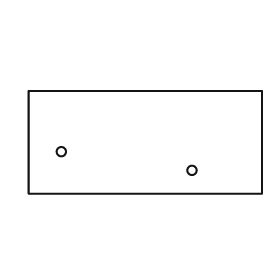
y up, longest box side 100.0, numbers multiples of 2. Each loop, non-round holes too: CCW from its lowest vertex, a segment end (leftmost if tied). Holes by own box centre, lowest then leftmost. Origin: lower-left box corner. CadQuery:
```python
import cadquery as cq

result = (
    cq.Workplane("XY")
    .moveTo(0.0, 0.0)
    .lineTo(100.0, 0.0)
    .lineTo(100.0, 44.0)
    .lineTo(0.0, 44.0)
    .close()
    .moveTo(70.0, 10.0)
    .circle(2.0)
    .moveTo(14.0, 18.0)
    .circle(2.0)
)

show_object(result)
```